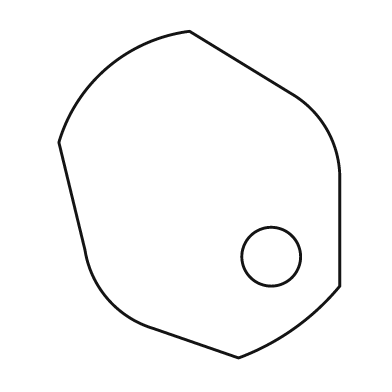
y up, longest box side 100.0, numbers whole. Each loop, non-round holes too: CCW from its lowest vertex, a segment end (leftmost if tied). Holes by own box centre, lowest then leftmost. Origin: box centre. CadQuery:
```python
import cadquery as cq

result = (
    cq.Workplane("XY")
    .moveTo(12.0, -50.0)
    .threePointArc((29.0, -41.0), (43.0, -28.0))
    .lineTo(43.0, 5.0)
    .threePointArc((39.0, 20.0), (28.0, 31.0))
    .lineTo(-3.0, 50.0)
    .threePointArc((-28.0, 39.0), (-43.0, 16.0))
    .lineTo(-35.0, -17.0)
    .threePointArc((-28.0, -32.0), (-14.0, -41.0))
    .close()
    .moveTo(22.0, -19.0)
    .circle(9.0)
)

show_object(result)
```